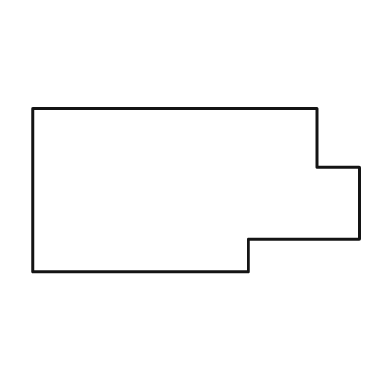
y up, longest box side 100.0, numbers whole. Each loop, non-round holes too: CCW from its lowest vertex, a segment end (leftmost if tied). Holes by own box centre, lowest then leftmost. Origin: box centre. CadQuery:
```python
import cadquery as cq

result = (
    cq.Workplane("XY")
    .moveTo(-50.0, -25.0)
    .lineTo(16.0, -25.0)
    .lineTo(16.0, -15.0)
    .lineTo(50.0, -15.0)
    .lineTo(50.0, 7.0)
    .lineTo(37.0, 7.0)
    .lineTo(37.0, 25.0)
    .lineTo(-50.0, 25.0)
    .close()
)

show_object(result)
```